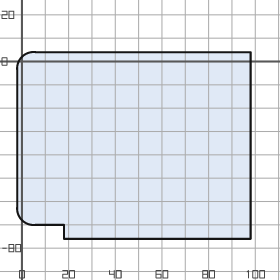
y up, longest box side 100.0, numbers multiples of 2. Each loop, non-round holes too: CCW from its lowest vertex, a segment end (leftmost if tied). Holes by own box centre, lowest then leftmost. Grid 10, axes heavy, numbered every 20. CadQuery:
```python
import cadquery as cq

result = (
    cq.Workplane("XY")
    .moveTo(18.0, -76.0)
    .lineTo(98.0, -76.0)
    .lineTo(98.0, 4.0)
    .lineTo(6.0, 4.0)
    .threePointArc((0.0, 2.0), (-2.0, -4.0))
    .lineTo(-2.0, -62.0)
    .threePointArc((0.0, -68.0), (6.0, -70.0))
    .lineTo(18.0, -70.0)
    .close()
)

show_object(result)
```